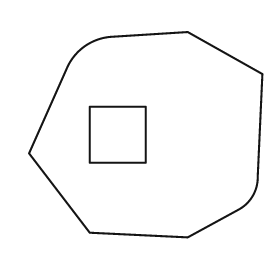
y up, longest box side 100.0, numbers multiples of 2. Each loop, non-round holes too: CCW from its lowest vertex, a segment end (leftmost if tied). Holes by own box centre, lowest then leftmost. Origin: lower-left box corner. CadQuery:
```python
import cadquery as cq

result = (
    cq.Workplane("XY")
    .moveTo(68.0, 0.0)
    .lineTo(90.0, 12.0)
    .threePointArc((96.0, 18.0), (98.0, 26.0))
    .lineTo(100.0, 70.0)
    .lineTo(68.0, 88.0)
    .lineTo(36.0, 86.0)
    .threePointArc((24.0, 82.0), (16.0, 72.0))
    .lineTo(0.0, 36.0)
    .lineTo(26.0, 2.0)
    .close()
    .moveTo(26.0, 32.0)
    .lineTo(50.0, 32.0)
    .lineTo(50.0, 56.0)
    .lineTo(26.0, 56.0)
    .close()
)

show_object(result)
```